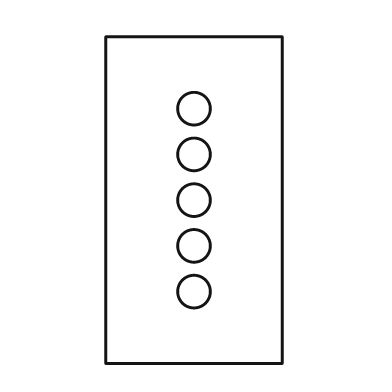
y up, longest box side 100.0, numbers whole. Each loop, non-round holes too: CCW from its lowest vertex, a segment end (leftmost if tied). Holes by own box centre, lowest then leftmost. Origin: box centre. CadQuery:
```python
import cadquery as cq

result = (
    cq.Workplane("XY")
    .moveTo(-27.0, -50.0)
    .lineTo(27.0, -50.0)
    .lineTo(27.0, 50.0)
    .lineTo(-27.0, 50.0)
    .close()
    .moveTo(0.0, -28.0)
    .circle(5.0)
    .moveTo(0.0, -14.0)
    .circle(5.0)
    .moveTo(0.0, 0.0)
    .circle(5.0)
    .moveTo(0.0, 14.0)
    .circle(5.0)
    .moveTo(0.0, 28.0)
    .circle(5.0)
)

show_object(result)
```